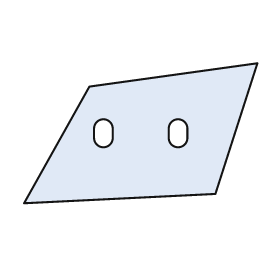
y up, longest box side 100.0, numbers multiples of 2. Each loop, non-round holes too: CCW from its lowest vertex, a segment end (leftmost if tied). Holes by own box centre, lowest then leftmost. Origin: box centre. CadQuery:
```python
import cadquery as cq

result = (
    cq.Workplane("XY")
    .moveTo(-50.0, -30.0)
    .lineTo(32.0, -26.0)
    .lineTo(50.0, 30.0)
    .lineTo(-22.0, 20.0)
    .close()
    .moveTo(-20.0, -2.0)
    .threePointArc((-16.0, -6.0), (-12.0, -2.0))
    .lineTo(-12.0, 2.0)
    .threePointArc((-16.0, 6.0), (-20.0, 2.0))
    .close()
    .moveTo(12.0, -2.0)
    .threePointArc((16.0, -6.0), (20.0, -2.0))
    .lineTo(20.0, 2.0)
    .threePointArc((16.0, 6.0), (12.0, 2.0))
    .close()
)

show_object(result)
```